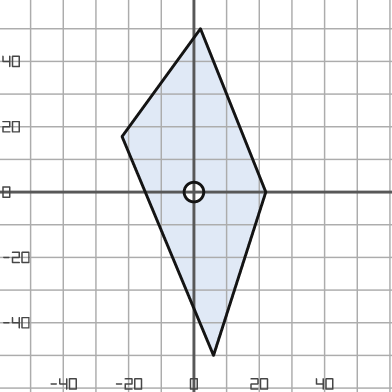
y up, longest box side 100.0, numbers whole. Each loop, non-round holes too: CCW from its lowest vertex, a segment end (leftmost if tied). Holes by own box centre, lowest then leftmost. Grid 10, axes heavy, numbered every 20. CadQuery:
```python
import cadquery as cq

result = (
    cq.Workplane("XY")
    .moveTo(6.0, -50.0)
    .lineTo(22.0, 0.0)
    .lineTo(2.0, 50.0)
    .lineTo(-22.0, 17.0)
    .close()
    .moveTo(0.0, 0.0)
    .circle(3.0)
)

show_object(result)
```